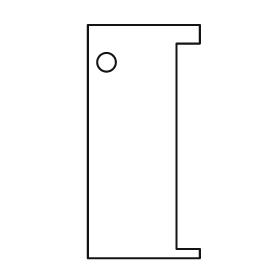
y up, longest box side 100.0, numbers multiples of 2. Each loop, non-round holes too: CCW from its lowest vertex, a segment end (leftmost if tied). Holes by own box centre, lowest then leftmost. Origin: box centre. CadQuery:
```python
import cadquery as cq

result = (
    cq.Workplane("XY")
    .moveTo(-24.0, -50.0)
    .lineTo(24.0, -50.0)
    .lineTo(24.0, -46.0)
    .lineTo(14.0, -46.0)
    .lineTo(14.0, 42.0)
    .lineTo(24.0, 42.0)
    .lineTo(24.0, 50.0)
    .lineTo(-24.0, 50.0)
    .close()
    .moveTo(-16.0, 34.0)
    .circle(4.0)
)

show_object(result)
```